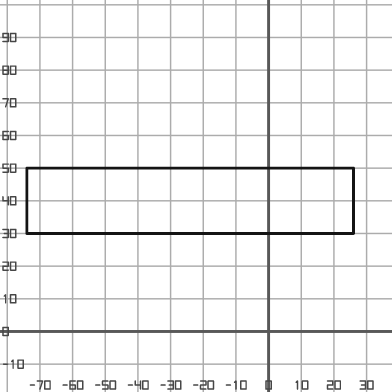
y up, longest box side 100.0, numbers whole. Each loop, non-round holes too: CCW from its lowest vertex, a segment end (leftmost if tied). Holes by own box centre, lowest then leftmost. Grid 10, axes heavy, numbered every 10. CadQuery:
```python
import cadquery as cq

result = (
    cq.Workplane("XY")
    .moveTo(-74.0, 30.0)
    .lineTo(26.0, 30.0)
    .lineTo(26.0, 50.0)
    .lineTo(-74.0, 50.0)
    .close()
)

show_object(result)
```